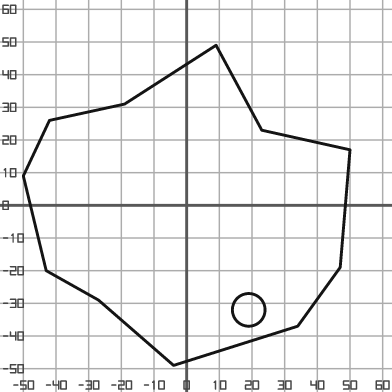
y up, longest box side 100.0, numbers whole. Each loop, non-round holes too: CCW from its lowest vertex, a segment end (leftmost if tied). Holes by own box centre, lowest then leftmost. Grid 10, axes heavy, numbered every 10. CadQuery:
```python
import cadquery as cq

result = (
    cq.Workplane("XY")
    .moveTo(-4.0, -49.0)
    .lineTo(34.0, -37.0)
    .lineTo(47.0, -19.0)
    .lineTo(50.0, 17.0)
    .lineTo(23.0, 23.0)
    .lineTo(9.0, 49.0)
    .lineTo(-19.0, 31.0)
    .lineTo(-42.0, 26.0)
    .lineTo(-50.0, 9.0)
    .lineTo(-43.0, -20.0)
    .lineTo(-27.0, -29.0)
    .close()
    .moveTo(19.0, -32.0)
    .circle(5.0)
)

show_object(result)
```